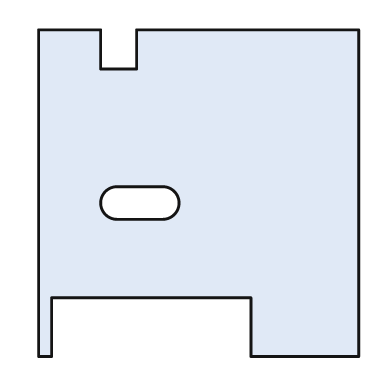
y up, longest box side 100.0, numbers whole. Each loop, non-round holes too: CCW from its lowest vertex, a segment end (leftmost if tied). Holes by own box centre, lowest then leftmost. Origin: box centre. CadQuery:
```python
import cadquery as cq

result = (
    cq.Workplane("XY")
    .moveTo(-49.0, -50.0)
    .lineTo(-45.0, -50.0)
    .lineTo(-45.0, -32.0)
    .lineTo(16.0, -32.0)
    .lineTo(16.0, -50.0)
    .lineTo(49.0, -50.0)
    .lineTo(49.0, 50.0)
    .lineTo(-19.0, 50.0)
    .lineTo(-19.0, 38.0)
    .lineTo(-30.0, 38.0)
    .lineTo(-30.0, 50.0)
    .lineTo(-49.0, 50.0)
    .close()
    .moveTo(-25.0, -8.0)
    .lineTo(-11.0, -8.0)
    .threePointArc((-6.0, -3.0), (-11.0, 2.0))
    .lineTo(-25.0, 2.0)
    .threePointArc((-30.0, -3.0), (-25.0, -8.0))
    .close()
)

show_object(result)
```